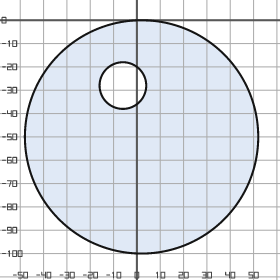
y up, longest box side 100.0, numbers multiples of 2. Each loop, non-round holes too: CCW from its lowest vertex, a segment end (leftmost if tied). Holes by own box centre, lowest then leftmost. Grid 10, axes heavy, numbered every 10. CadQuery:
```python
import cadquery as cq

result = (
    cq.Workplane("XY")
    .moveTo(2.0, -50.0)
    .circle(50.0)
    .moveTo(-6.0, -28.0)
    .circle(10.0)
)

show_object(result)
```